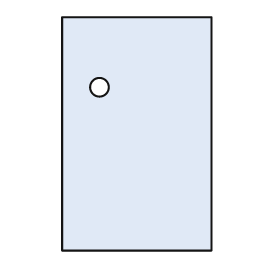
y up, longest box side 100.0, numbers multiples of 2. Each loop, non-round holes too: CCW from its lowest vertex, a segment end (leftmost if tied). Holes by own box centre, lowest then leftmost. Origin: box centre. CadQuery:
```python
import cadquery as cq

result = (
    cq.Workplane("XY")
    .moveTo(-32.0, -50.0)
    .lineTo(32.0, -50.0)
    .lineTo(32.0, 50.0)
    .lineTo(-32.0, 50.0)
    .close()
    .moveTo(-16.0, 20.0)
    .circle(4.0)
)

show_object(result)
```